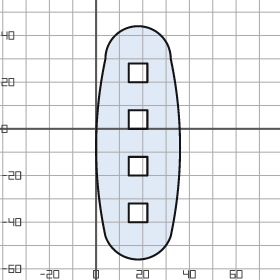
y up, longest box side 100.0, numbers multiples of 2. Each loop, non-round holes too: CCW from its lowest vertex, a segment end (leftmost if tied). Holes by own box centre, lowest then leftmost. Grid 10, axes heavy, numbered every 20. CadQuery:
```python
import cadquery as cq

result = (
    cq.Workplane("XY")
    .moveTo(4.0, -46.0)
    .threePointArc((18.0, -56.0), (32.0, -46.0))
    .threePointArc((36.0, -8.0), (32.0, 30.0))
    .threePointArc((18.0, 44.0), (4.0, 30.0))
    .threePointArc((0.0, -8.0), (4.0, -46.0))
    .close()
    .moveTo(14.0, -40.0)
    .lineTo(22.0, -40.0)
    .lineTo(22.0, -32.0)
    .lineTo(14.0, -32.0)
    .close()
    .moveTo(14.0, -20.0)
    .lineTo(22.0, -20.0)
    .lineTo(22.0, -12.0)
    .lineTo(14.0, -12.0)
    .close()
    .moveTo(14.0, 0.0)
    .lineTo(22.0, 0.0)
    .lineTo(22.0, 8.0)
    .lineTo(14.0, 8.0)
    .close()
    .moveTo(14.0, 20.0)
    .lineTo(22.0, 20.0)
    .lineTo(22.0, 28.0)
    .lineTo(14.0, 28.0)
    .close()
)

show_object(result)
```